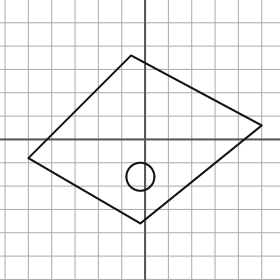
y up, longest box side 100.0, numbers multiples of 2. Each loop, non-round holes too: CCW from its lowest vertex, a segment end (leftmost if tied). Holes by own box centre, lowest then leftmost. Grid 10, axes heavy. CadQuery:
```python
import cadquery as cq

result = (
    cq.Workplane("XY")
    .moveTo(-2.0, -36.0)
    .lineTo(50.0, 6.0)
    .lineTo(-6.0, 36.0)
    .lineTo(-50.0, -8.0)
    .close()
    .moveTo(-2.0, -16.0)
    .circle(6.0)
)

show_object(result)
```